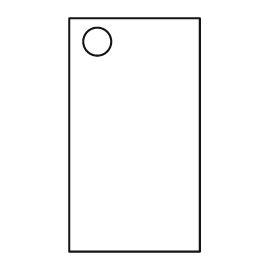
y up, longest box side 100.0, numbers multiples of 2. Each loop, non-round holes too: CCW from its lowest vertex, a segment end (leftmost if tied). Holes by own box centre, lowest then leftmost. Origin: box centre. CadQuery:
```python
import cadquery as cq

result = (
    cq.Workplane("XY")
    .moveTo(-28.0, -50.0)
    .lineTo(28.0, -50.0)
    .lineTo(28.0, 50.0)
    .lineTo(-28.0, 50.0)
    .close()
    .moveTo(-16.0, 40.0)
    .circle(6.0)
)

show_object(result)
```